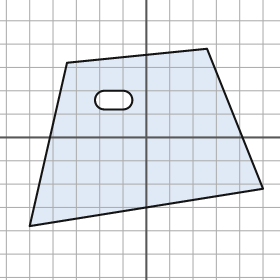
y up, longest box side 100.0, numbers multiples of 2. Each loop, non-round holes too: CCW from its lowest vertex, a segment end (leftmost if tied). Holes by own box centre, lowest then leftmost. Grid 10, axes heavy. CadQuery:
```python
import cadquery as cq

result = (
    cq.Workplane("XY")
    .moveTo(-50.0, -38.0)
    .lineTo(50.0, -22.0)
    .lineTo(26.0, 38.0)
    .lineTo(-34.0, 32.0)
    .close()
    .moveTo(-18.0, 12.0)
    .lineTo(-10.0, 12.0)
    .threePointArc((-6.0, 16.0), (-10.0, 20.0))
    .lineTo(-18.0, 20.0)
    .threePointArc((-22.0, 16.0), (-18.0, 12.0))
    .close()
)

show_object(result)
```